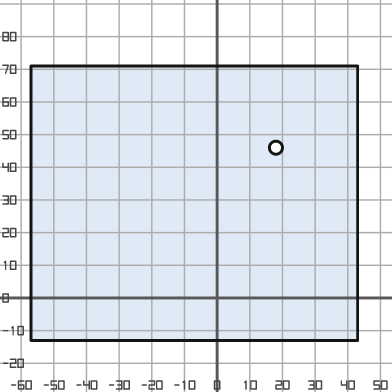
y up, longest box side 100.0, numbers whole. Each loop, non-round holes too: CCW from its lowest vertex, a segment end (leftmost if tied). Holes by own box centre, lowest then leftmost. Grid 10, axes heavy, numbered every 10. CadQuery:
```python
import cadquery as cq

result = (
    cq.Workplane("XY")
    .moveTo(-57.0, -13.0)
    .lineTo(43.0, -13.0)
    .lineTo(43.0, 71.0)
    .lineTo(-57.0, 71.0)
    .close()
    .moveTo(18.0, 46.0)
    .circle(2.0)
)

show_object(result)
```